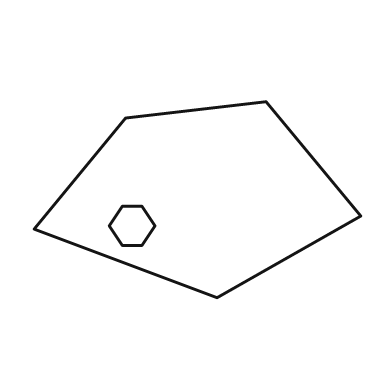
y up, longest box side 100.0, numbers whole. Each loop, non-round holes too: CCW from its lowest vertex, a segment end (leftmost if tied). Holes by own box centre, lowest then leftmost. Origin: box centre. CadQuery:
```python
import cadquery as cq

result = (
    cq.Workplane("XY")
    .moveTo(6.0, -30.0)
    .lineTo(50.0, -5.0)
    .lineTo(21.0, 30.0)
    .lineTo(-22.0, 25.0)
    .lineTo(-50.0, -9.0)
    .close()
    .moveTo(-23.0, -14.0)
    .lineTo(-17.0, -14.0)
    .lineTo(-13.0, -8.0)
    .lineTo(-17.0, -2.0)
    .lineTo(-23.0, -2.0)
    .lineTo(-27.0, -8.0)
    .close()
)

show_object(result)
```